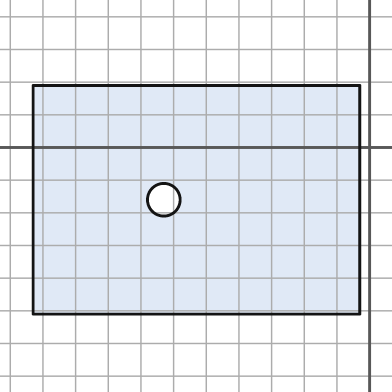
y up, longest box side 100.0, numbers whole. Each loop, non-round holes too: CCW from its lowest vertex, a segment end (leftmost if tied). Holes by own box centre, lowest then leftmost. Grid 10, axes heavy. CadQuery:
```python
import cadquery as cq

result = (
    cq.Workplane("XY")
    .moveTo(-103.0, -51.0)
    .lineTo(-3.0, -51.0)
    .lineTo(-3.0, 19.0)
    .lineTo(-103.0, 19.0)
    .close()
    .moveTo(-63.0, -16.0)
    .circle(5.0)
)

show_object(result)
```